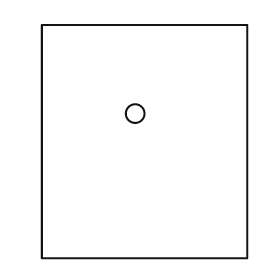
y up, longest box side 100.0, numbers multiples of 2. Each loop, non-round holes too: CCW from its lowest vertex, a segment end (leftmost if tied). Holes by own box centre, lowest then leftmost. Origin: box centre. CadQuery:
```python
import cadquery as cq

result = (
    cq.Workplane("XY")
    .moveTo(-44.0, -50.0)
    .lineTo(44.0, -50.0)
    .lineTo(44.0, 50.0)
    .lineTo(-44.0, 50.0)
    .close()
    .moveTo(-4.0, 12.0)
    .circle(4.0)
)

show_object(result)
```